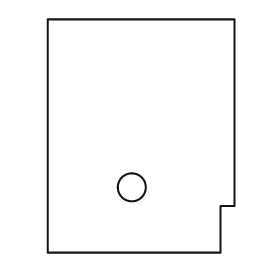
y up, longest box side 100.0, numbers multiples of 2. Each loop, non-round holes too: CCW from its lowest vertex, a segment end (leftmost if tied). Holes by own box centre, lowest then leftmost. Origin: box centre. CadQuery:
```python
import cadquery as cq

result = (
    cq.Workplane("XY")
    .moveTo(-40.0, -50.0)
    .lineTo(34.0, -50.0)
    .lineTo(34.0, -30.0)
    .lineTo(40.0, -30.0)
    .lineTo(40.0, 50.0)
    .lineTo(-40.0, 50.0)
    .close()
    .moveTo(-4.0, -22.0)
    .circle(6.0)
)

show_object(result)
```